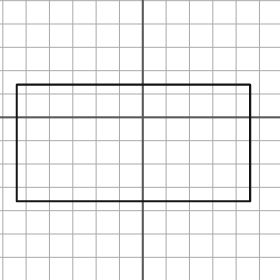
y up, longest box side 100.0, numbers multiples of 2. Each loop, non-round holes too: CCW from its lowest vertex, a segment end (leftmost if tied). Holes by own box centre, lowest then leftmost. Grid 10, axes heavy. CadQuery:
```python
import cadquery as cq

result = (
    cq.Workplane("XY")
    .moveTo(-54.0, -36.0)
    .lineTo(46.0, -36.0)
    .lineTo(46.0, 14.0)
    .lineTo(-54.0, 14.0)
    .close()
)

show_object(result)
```